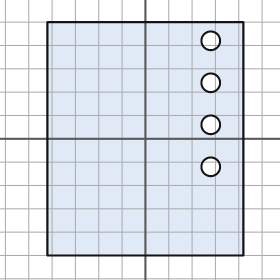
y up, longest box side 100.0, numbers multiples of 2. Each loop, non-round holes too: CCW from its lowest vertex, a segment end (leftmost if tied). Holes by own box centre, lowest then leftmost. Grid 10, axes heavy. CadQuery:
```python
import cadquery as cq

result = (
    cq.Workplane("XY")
    .moveTo(-42.0, -50.0)
    .lineTo(42.0, -50.0)
    .lineTo(42.0, 50.0)
    .lineTo(-42.0, 50.0)
    .close()
    .moveTo(28.0, -12.0)
    .circle(4.0)
    .moveTo(28.0, 6.0)
    .circle(4.0)
    .moveTo(28.0, 24.0)
    .circle(4.0)
    .moveTo(28.0, 42.0)
    .circle(4.0)
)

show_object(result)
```